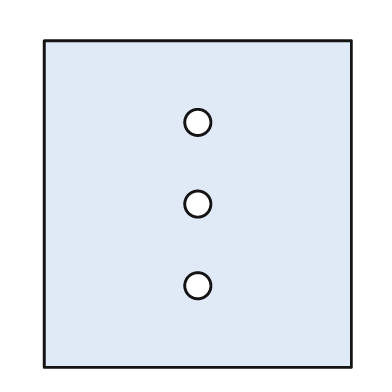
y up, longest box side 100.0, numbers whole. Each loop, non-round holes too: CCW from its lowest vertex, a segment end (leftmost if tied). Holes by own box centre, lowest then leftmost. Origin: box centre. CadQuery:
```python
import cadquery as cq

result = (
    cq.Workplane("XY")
    .moveTo(-47.0, -50.0)
    .lineTo(47.0, -50.0)
    .lineTo(47.0, 50.0)
    .lineTo(-47.0, 50.0)
    .close()
    .moveTo(0.0, -25.0)
    .circle(4.0)
    .moveTo(0.0, 0.0)
    .circle(4.0)
    .moveTo(0.0, 25.0)
    .circle(4.0)
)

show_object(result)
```